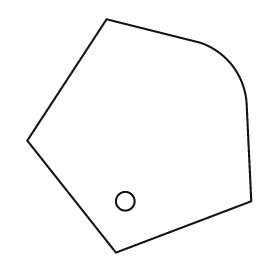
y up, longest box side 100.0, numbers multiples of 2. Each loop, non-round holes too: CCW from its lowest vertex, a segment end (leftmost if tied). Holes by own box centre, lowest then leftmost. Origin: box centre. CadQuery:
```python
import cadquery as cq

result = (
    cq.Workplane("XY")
    .moveTo(-10.0, -50.0)
    .lineTo(48.0, -28.0)
    .lineTo(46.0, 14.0)
    .threePointArc((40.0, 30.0), (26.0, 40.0))
    .lineTo(-14.0, 50.0)
    .lineTo(-48.0, -2.0)
    .close()
    .moveTo(-6.0, -28.0)
    .circle(4.0)
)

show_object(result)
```